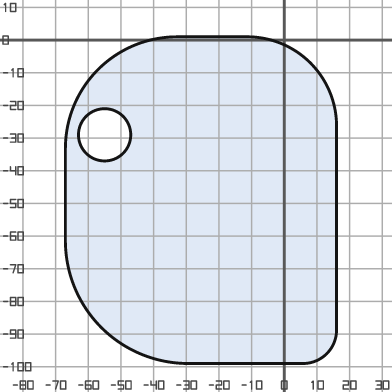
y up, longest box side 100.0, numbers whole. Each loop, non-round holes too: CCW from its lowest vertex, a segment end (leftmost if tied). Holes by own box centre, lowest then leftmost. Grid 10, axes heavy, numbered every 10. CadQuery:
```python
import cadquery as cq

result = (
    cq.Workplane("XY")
    .moveTo(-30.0, -99.0)
    .lineTo(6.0, -99.0)
    .threePointArc((13.0, -96.0), (16.0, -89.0))
    .lineTo(16.0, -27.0)
    .threePointArc((8.0, -7.0), (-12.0, 1.0))
    .lineTo(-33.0, 1.0)
    .threePointArc((-57.0, -9.0), (-67.0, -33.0))
    .lineTo(-67.0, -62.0)
    .threePointArc((-56.0, -88.0), (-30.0, -99.0))
    .close()
    .moveTo(-55.0, -29.0)
    .circle(8.0)
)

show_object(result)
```